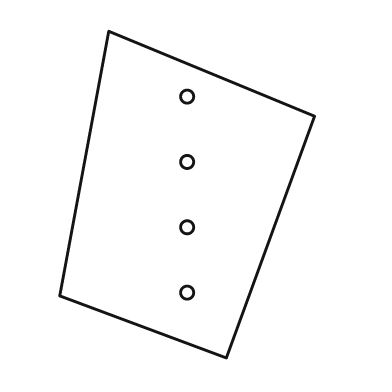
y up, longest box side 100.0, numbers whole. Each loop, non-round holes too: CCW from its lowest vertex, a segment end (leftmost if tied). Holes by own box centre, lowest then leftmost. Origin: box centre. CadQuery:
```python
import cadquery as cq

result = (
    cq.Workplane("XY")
    .moveTo(12.0, -50.0)
    .lineTo(39.0, 24.0)
    .lineTo(-24.0, 50.0)
    .lineTo(-39.0, -31.0)
    .close()
    .moveTo(0.0, -30.0)
    .circle(2.0)
    .moveTo(0.0, -10.0)
    .circle(2.0)
    .moveTo(0.0, 10.0)
    .circle(2.0)
    .moveTo(0.0, 30.0)
    .circle(2.0)
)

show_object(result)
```